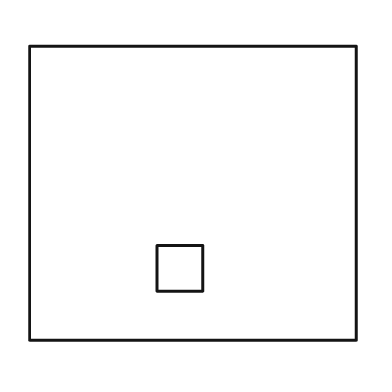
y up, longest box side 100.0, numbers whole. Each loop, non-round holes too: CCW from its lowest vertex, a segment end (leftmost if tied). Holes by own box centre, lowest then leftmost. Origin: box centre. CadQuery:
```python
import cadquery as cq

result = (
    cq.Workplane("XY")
    .moveTo(-50.0, -45.0)
    .lineTo(50.0, -45.0)
    .lineTo(50.0, 45.0)
    .lineTo(-50.0, 45.0)
    .close()
    .moveTo(-11.0, -30.0)
    .lineTo(3.0, -30.0)
    .lineTo(3.0, -16.0)
    .lineTo(-11.0, -16.0)
    .close()
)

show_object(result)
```